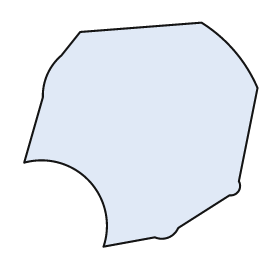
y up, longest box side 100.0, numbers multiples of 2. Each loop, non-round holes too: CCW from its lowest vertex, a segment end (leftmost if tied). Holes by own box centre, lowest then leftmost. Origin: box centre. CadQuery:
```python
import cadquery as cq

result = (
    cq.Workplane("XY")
    .moveTo(-16.0, -48.0)
    .lineTo(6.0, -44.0)
    .threePointArc((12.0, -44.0), (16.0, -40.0))
    .lineTo(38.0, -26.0)
    .threePointArc((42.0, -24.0), (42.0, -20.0))
    .lineTo(50.0, 20.0)
    .threePointArc((40.0, 36.0), (26.0, 48.0))
    .lineTo(-26.0, 44.0)
    .lineTo(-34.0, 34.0)
    .threePointArc((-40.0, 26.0), (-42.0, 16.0))
    .lineTo(-50.0, -12.0)
    .threePointArc((-22.0, -20.0), (-16.0, -48.0))
    .close()
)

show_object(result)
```